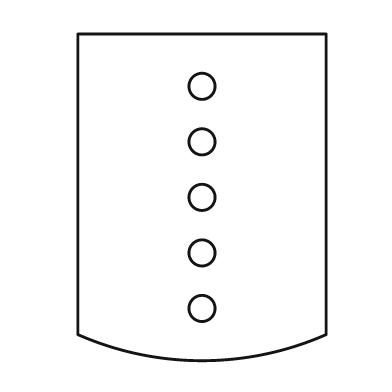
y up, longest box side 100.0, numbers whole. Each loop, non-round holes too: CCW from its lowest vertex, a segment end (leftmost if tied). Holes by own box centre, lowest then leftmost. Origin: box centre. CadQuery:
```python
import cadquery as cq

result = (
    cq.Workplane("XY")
    .moveTo(-38.0, -42.0)
    .threePointArc((0.0, -50.0), (38.0, -42.0))
    .lineTo(38.0, 50.0)
    .lineTo(-38.0, 50.0)
    .close()
    .moveTo(0.0, -34.0)
    .circle(4.0)
    .moveTo(0.0, -17.0)
    .circle(4.0)
    .moveTo(0.0, 0.0)
    .circle(4.0)
    .moveTo(0.0, 17.0)
    .circle(4.0)
    .moveTo(0.0, 34.0)
    .circle(4.0)
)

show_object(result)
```